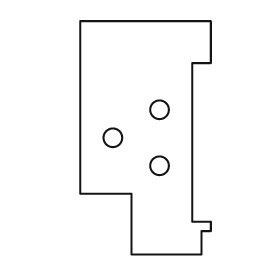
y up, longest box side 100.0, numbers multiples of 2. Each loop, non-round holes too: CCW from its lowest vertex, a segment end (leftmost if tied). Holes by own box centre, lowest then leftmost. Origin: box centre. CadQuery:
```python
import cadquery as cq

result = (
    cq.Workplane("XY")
    .moveTo(-6.0, -50.0)
    .lineTo(24.0, -50.0)
    .lineTo(24.0, -40.0)
    .lineTo(28.0, -40.0)
    .lineTo(28.0, -36.0)
    .lineTo(20.0, -36.0)
    .lineTo(20.0, 32.0)
    .lineTo(28.0, 32.0)
    .lineTo(28.0, 50.0)
    .lineTo(-28.0, 50.0)
    .lineTo(-28.0, -24.0)
    .lineTo(-6.0, -24.0)
    .close()
    .moveTo(6.0, -12.0)
    .circle(4.0)
    .moveTo(-14.0, 0.0)
    .circle(4.0)
    .moveTo(6.0, 12.0)
    .circle(4.0)
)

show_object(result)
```